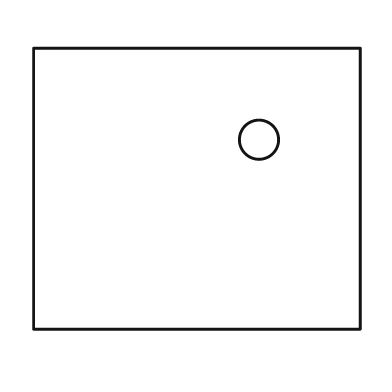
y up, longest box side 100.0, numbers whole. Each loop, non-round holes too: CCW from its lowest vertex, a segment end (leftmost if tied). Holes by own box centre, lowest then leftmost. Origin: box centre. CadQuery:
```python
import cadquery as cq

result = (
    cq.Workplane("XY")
    .moveTo(-50.0, -43.0)
    .lineTo(50.0, -43.0)
    .lineTo(50.0, 43.0)
    .lineTo(-50.0, 43.0)
    .close()
    .moveTo(19.0, 15.0)
    .circle(6.0)
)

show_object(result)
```